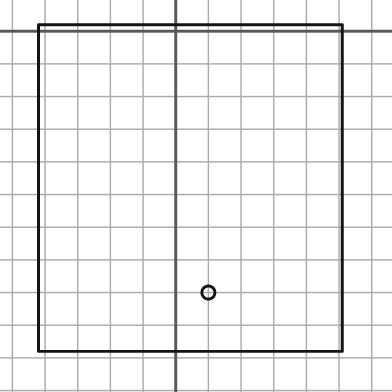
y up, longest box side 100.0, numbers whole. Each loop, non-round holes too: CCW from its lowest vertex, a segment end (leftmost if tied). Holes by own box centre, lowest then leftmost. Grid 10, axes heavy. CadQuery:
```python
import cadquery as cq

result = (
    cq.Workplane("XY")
    .moveTo(-42.0, -98.0)
    .lineTo(51.0, -98.0)
    .lineTo(51.0, 2.0)
    .lineTo(-42.0, 2.0)
    .close()
    .moveTo(10.0, -80.0)
    .circle(2.0)
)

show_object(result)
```